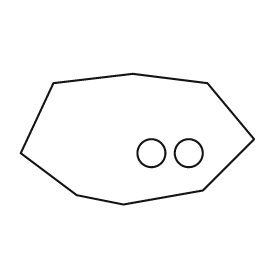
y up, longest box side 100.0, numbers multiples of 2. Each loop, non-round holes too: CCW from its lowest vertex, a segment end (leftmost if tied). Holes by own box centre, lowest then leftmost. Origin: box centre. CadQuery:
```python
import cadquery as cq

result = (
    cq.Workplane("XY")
    .moveTo(-6.0, -28.0)
    .lineTo(28.0, -22.0)
    .lineTo(50.0, 0.0)
    .lineTo(30.0, 24.0)
    .lineTo(-2.0, 28.0)
    .lineTo(-36.0, 24.0)
    .lineTo(-50.0, -6.0)
    .lineTo(-26.0, -24.0)
    .close()
    .moveTo(6.0, -6.0)
    .circle(6.0)
    .moveTo(22.0, -6.0)
    .circle(6.0)
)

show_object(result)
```